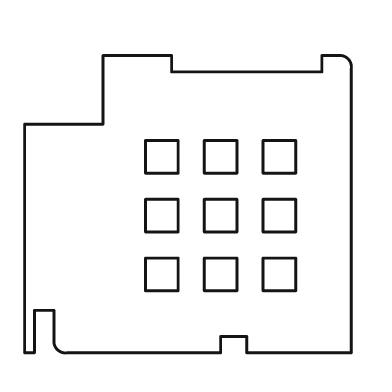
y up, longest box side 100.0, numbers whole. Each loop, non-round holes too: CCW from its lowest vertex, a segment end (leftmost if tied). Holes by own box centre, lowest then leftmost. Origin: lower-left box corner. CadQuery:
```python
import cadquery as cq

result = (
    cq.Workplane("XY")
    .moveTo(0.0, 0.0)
    .lineTo(3.0, 0.0)
    .lineTo(3.0, 13.0)
    .lineTo(9.0, 13.0)
    .lineTo(9.0, 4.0)
    .threePointArc((10.0, 1.0), (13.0, 0.0))
    .lineTo(60.0, 0.0)
    .lineTo(60.0, 5.0)
    .lineTo(68.0, 5.0)
    .lineTo(68.0, 0.0)
    .lineTo(100.0, 0.0)
    .lineTo(100.0, 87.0)
    .threePointArc((99.0, 90.0), (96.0, 91.0))
    .lineTo(91.0, 91.0)
    .lineTo(91.0, 86.0)
    .lineTo(45.0, 86.0)
    .lineTo(45.0, 91.0)
    .lineTo(24.0, 91.0)
    .lineTo(24.0, 70.0)
    .lineTo(0.0, 70.0)
    .close()
    .moveTo(37.0, 19.0)
    .lineTo(47.0, 19.0)
    .lineTo(47.0, 29.0)
    .lineTo(37.0, 29.0)
    .close()
    .moveTo(55.0, 19.0)
    .lineTo(65.0, 19.0)
    .lineTo(65.0, 29.0)
    .lineTo(55.0, 29.0)
    .close()
    .moveTo(73.0, 19.0)
    .lineTo(83.0, 19.0)
    .lineTo(83.0, 29.0)
    .lineTo(73.0, 29.0)
    .close()
    .moveTo(37.0, 37.0)
    .lineTo(47.0, 37.0)
    .lineTo(47.0, 47.0)
    .lineTo(37.0, 47.0)
    .close()
    .moveTo(55.0, 37.0)
    .lineTo(65.0, 37.0)
    .lineTo(65.0, 47.0)
    .lineTo(55.0, 47.0)
    .close()
    .moveTo(73.0, 37.0)
    .lineTo(83.0, 37.0)
    .lineTo(83.0, 47.0)
    .lineTo(73.0, 47.0)
    .close()
    .moveTo(37.0, 55.0)
    .lineTo(47.0, 55.0)
    .lineTo(47.0, 65.0)
    .lineTo(37.0, 65.0)
    .close()
    .moveTo(55.0, 55.0)
    .lineTo(65.0, 55.0)
    .lineTo(65.0, 65.0)
    .lineTo(55.0, 65.0)
    .close()
    .moveTo(73.0, 55.0)
    .lineTo(83.0, 55.0)
    .lineTo(83.0, 65.0)
    .lineTo(73.0, 65.0)
    .close()
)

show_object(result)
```